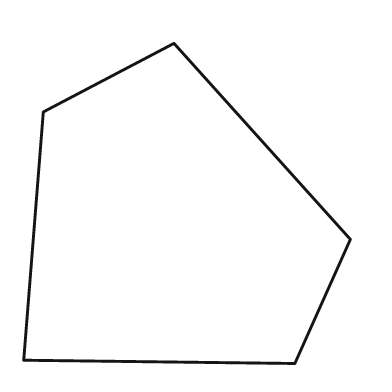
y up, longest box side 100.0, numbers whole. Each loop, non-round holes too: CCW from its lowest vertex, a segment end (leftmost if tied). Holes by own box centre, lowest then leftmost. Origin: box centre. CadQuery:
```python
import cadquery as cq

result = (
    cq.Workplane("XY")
    .moveTo(33.0, -49.0)
    .lineTo(50.0, -11.0)
    .lineTo(-4.0, 49.0)
    .lineTo(-44.0, 28.0)
    .lineTo(-50.0, -48.0)
    .close()
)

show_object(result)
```